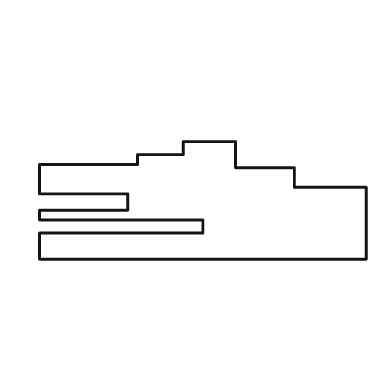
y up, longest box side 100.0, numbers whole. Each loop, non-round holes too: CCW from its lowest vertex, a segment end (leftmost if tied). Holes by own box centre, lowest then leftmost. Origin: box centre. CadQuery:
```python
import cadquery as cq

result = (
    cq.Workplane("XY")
    .moveTo(-50.0, -18.0)
    .lineTo(50.0, -18.0)
    .lineTo(50.0, 4.0)
    .lineTo(28.0, 4.0)
    .lineTo(28.0, 10.0)
    .lineTo(10.0, 10.0)
    .lineTo(10.0, 18.0)
    .lineTo(-6.0, 18.0)
    .lineTo(-6.0, 14.0)
    .lineTo(-20.0, 14.0)
    .lineTo(-20.0, 11.0)
    .lineTo(-50.0, 11.0)
    .lineTo(-50.0, 2.0)
    .lineTo(-23.0, 2.0)
    .lineTo(-23.0, -3.0)
    .lineTo(-50.0, -3.0)
    .lineTo(-50.0, -6.0)
    .lineTo(0.0, -6.0)
    .lineTo(0.0, -10.0)
    .lineTo(-50.0, -10.0)
    .close()
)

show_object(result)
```